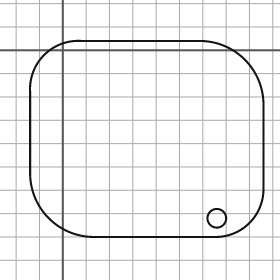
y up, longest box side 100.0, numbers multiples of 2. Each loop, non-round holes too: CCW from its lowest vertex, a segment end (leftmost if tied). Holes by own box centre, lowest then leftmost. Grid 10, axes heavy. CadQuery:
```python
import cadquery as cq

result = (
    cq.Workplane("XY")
    .moveTo(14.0, -80.0)
    .lineTo(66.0, -80.0)
    .threePointArc((80.0, -74.0), (86.0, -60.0))
    .lineTo(86.0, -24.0)
    .threePointArc((78.0, -4.0), (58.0, 4.0))
    .lineTo(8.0, 4.0)
    .threePointArc((-8.0, -2.0), (-14.0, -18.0))
    .lineTo(-14.0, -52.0)
    .threePointArc((-6.0, -72.0), (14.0, -80.0))
    .close()
    .moveTo(66.0, -72.0)
    .circle(4.0)
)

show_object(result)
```